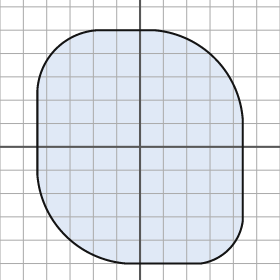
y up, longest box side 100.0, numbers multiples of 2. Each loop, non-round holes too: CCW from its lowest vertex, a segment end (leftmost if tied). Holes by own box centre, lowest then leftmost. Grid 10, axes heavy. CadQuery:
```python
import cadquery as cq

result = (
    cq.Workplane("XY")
    .moveTo(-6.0, -50.0)
    .lineTo(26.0, -50.0)
    .threePointArc((38.0, -44.0), (44.0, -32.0))
    .lineTo(44.0, 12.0)
    .threePointArc((32.0, 38.0), (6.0, 50.0))
    .lineTo(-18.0, 50.0)
    .threePointArc((-36.0, 42.0), (-44.0, 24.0))
    .lineTo(-44.0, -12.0)
    .threePointArc((-32.0, -38.0), (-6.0, -50.0))
    .close()
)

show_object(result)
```